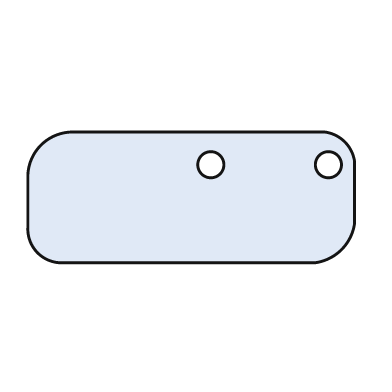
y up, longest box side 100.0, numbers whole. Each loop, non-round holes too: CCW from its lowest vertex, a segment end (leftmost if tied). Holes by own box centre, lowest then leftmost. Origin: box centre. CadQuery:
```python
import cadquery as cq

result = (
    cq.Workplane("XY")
    .moveTo(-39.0, -20.0)
    .lineTo(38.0, -20.0)
    .threePointArc((46.0, -16.0), (50.0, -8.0))
    .lineTo(50.0, 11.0)
    .threePointArc((47.0, 17.0), (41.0, 20.0))
    .lineTo(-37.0, 20.0)
    .threePointArc((-46.0, 16.0), (-50.0, 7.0))
    .lineTo(-50.0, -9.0)
    .threePointArc((-47.0, -17.0), (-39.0, -20.0))
    .close()
    .moveTo(6.0, 10.0)
    .circle(4.0)
    .moveTo(42.0, 10.0)
    .circle(4.0)
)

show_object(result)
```